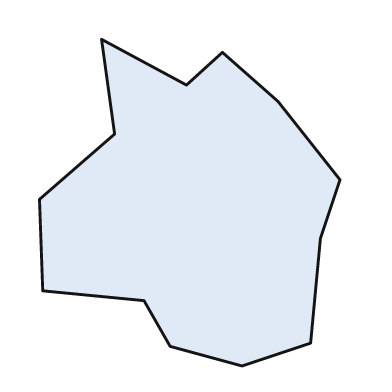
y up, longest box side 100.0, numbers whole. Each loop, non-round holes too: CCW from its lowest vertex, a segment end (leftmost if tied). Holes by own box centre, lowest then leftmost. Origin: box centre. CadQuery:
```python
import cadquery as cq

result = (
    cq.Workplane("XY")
    .moveTo(16.0, -50.0)
    .lineTo(37.0, -43.0)
    .lineTo(40.0, -11.0)
    .lineTo(46.0, 7.0)
    .lineTo(27.0, 31.0)
    .lineTo(10.0, 46.0)
    .lineTo(-1.0, 36.0)
    .lineTo(-27.0, 50.0)
    .lineTo(-23.0, 21.0)
    .lineTo(-46.0, 1.0)
    .lineTo(-45.0, -27.0)
    .lineTo(-14.0, -30.0)
    .lineTo(-6.0, -44.0)
    .close()
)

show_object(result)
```